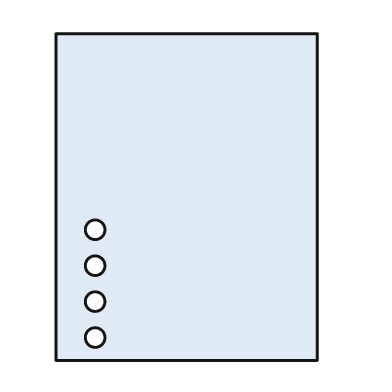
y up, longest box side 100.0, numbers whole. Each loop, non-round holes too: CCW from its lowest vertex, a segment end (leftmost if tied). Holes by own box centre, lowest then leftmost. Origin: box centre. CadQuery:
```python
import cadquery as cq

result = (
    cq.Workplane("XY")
    .moveTo(-40.0, -50.0)
    .lineTo(40.0, -50.0)
    .lineTo(40.0, 50.0)
    .lineTo(-40.0, 50.0)
    .close()
    .moveTo(-28.0, -43.0)
    .circle(3.0)
    .moveTo(-28.0, -32.0)
    .circle(3.0)
    .moveTo(-28.0, -21.0)
    .circle(3.0)
    .moveTo(-28.0, -10.0)
    .circle(3.0)
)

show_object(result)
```